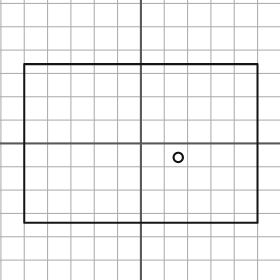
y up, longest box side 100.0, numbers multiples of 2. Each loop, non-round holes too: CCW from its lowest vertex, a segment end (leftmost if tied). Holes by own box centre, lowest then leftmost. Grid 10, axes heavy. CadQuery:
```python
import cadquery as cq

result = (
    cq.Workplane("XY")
    .moveTo(-50.0, -34.0)
    .lineTo(50.0, -34.0)
    .lineTo(50.0, 34.0)
    .lineTo(-50.0, 34.0)
    .close()
    .moveTo(16.0, -6.0)
    .circle(2.0)
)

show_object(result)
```